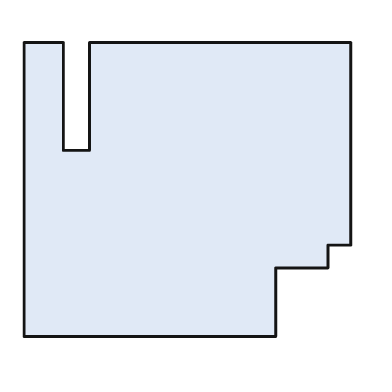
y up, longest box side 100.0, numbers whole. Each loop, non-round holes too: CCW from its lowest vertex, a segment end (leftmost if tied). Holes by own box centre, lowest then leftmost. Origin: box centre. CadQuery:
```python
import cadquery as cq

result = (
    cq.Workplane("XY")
    .moveTo(-50.0, -45.0)
    .lineTo(27.0, -45.0)
    .lineTo(27.0, -24.0)
    .lineTo(43.0, -24.0)
    .lineTo(43.0, -17.0)
    .lineTo(50.0, -17.0)
    .lineTo(50.0, 45.0)
    .lineTo(-30.0, 45.0)
    .lineTo(-30.0, 12.0)
    .lineTo(-38.0, 12.0)
    .lineTo(-38.0, 45.0)
    .lineTo(-50.0, 45.0)
    .close()
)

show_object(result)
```